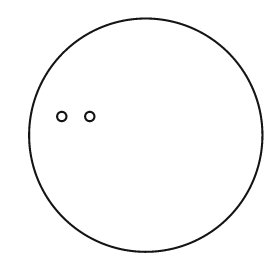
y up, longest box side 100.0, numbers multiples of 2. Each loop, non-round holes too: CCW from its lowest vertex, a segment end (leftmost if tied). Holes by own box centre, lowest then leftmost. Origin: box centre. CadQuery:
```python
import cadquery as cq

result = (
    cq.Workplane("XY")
    .moveTo(0.0, 0.0)
    .circle(50.0)
    .moveTo(-36.0, 8.0)
    .circle(2.0)
    .moveTo(-24.0, 8.0)
    .circle(2.0)
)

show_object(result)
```